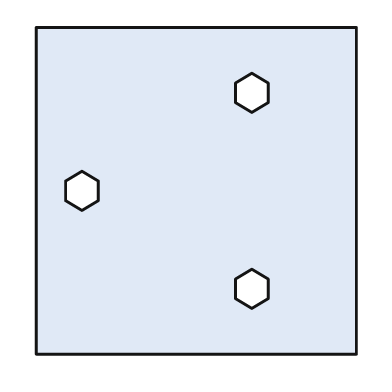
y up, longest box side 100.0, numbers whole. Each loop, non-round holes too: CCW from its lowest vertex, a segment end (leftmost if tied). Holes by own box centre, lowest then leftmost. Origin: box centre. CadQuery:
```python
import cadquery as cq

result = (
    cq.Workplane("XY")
    .moveTo(-49.0, -50.0)
    .lineTo(49.0, -50.0)
    .lineTo(49.0, 50.0)
    .lineTo(-49.0, 50.0)
    .close()
    .moveTo(17.0, -36.0)
    .lineTo(22.0, -33.0)
    .lineTo(22.0, -27.0)
    .lineTo(17.0, -24.0)
    .lineTo(12.0, -27.0)
    .lineTo(12.0, -33.0)
    .close()
    .moveTo(-35.0, -6.0)
    .lineTo(-30.0, -3.0)
    .lineTo(-30.0, 3.0)
    .lineTo(-35.0, 6.0)
    .lineTo(-40.0, 3.0)
    .lineTo(-40.0, -3.0)
    .close()
    .moveTo(17.0, 24.0)
    .lineTo(22.0, 27.0)
    .lineTo(22.0, 33.0)
    .lineTo(17.0, 36.0)
    .lineTo(12.0, 33.0)
    .lineTo(12.0, 27.0)
    .close()
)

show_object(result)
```